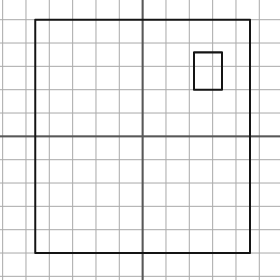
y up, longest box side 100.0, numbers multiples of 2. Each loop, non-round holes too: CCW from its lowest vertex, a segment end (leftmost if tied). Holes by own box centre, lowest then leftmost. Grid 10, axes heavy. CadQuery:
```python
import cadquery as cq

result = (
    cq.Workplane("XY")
    .moveTo(-46.0, -50.0)
    .lineTo(46.0, -50.0)
    .lineTo(46.0, 50.0)
    .lineTo(-46.0, 50.0)
    .close()
    .moveTo(22.0, 20.0)
    .lineTo(34.0, 20.0)
    .lineTo(34.0, 36.0)
    .lineTo(22.0, 36.0)
    .close()
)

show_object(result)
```